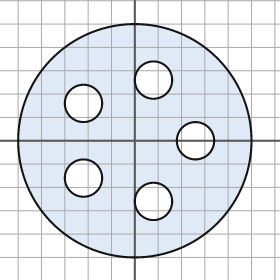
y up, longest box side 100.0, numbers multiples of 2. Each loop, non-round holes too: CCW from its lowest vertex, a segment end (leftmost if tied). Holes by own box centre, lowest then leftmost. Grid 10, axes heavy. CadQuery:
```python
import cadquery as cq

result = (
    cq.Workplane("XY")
    .moveTo(0.0, 0.0)
    .circle(50.0)
    .moveTo(8.0, -26.0)
    .circle(8.0)
    .moveTo(-22.0, -16.0)
    .circle(8.0)
    .moveTo(26.0, 0.0)
    .circle(8.0)
    .moveTo(-22.0, 16.0)
    .circle(8.0)
    .moveTo(8.0, 26.0)
    .circle(8.0)
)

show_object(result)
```